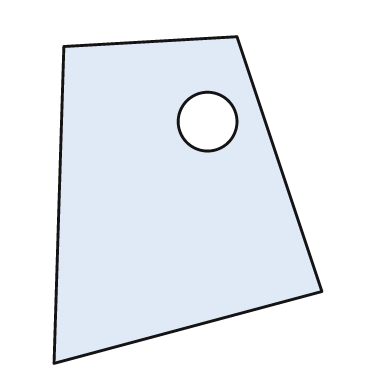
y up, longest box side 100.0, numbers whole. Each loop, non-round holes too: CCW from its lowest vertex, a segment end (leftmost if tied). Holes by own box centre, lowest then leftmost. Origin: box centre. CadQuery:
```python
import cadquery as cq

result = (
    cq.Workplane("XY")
    .moveTo(-41.0, -50.0)
    .lineTo(41.0, -28.0)
    .lineTo(15.0, 50.0)
    .lineTo(-38.0, 47.0)
    .close()
    .moveTo(6.0, 24.0)
    .circle(9.0)
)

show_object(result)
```